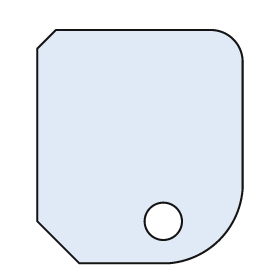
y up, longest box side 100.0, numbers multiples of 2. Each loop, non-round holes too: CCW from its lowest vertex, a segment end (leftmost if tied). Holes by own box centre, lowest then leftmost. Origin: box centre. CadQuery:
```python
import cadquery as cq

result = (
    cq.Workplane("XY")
    .moveTo(-26.0, -50.0)
    .lineTo(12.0, -50.0)
    .threePointArc((34.0, -40.0), (44.0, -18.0))
    .lineTo(44.0, 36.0)
    .threePointArc((40.0, 46.0), (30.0, 50.0))
    .lineTo(-36.0, 50.0)
    .lineTo(-44.0, 42.0)
    .lineTo(-44.0, -32.0)
    .close()
    .moveTo(10.0, -32.0)
    .circle(8.0)
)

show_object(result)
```